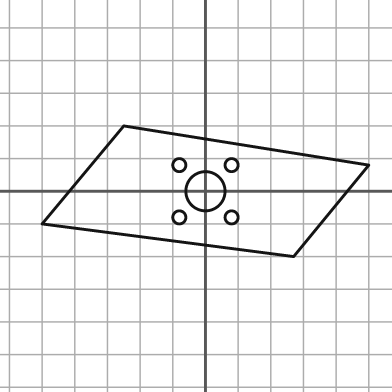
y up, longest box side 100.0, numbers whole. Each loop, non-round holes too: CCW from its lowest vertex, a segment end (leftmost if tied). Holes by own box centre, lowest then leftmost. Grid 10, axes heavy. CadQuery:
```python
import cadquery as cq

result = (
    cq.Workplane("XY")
    .moveTo(27.0, -20.0)
    .lineTo(50.0, 8.0)
    .lineTo(-25.0, 20.0)
    .lineTo(-50.0, -10.0)
    .close()
    .moveTo(-8.0, -8.0)
    .circle(2.0)
    .moveTo(8.0, -8.0)
    .circle(2.0)
    .moveTo(0.0, 0.0)
    .circle(6.0)
    .moveTo(-8.0, 8.0)
    .circle(2.0)
    .moveTo(8.0, 8.0)
    .circle(2.0)
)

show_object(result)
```